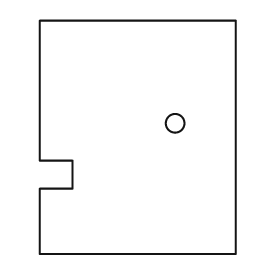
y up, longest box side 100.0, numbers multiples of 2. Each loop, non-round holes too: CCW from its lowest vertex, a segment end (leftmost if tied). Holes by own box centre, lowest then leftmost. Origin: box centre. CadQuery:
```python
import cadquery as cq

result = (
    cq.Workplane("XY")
    .moveTo(-42.0, -50.0)
    .lineTo(42.0, -50.0)
    .lineTo(42.0, 50.0)
    .lineTo(-42.0, 50.0)
    .lineTo(-42.0, -10.0)
    .lineTo(-28.0, -10.0)
    .lineTo(-28.0, -22.0)
    .lineTo(-42.0, -22.0)
    .close()
    .moveTo(16.0, 6.0)
    .circle(4.0)
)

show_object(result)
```